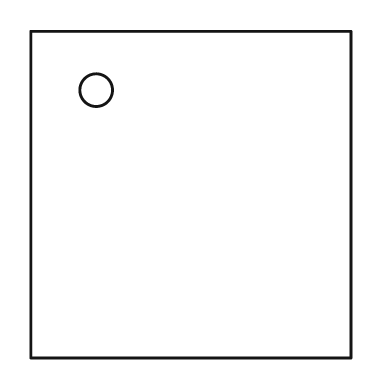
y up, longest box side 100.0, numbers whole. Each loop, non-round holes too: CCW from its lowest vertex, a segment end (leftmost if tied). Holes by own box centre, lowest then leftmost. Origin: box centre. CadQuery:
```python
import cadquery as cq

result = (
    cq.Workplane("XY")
    .moveTo(-49.0, -50.0)
    .lineTo(49.0, -50.0)
    .lineTo(49.0, 50.0)
    .lineTo(-49.0, 50.0)
    .close()
    .moveTo(-29.0, 32.0)
    .circle(5.0)
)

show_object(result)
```